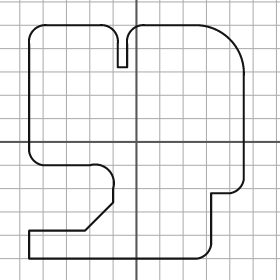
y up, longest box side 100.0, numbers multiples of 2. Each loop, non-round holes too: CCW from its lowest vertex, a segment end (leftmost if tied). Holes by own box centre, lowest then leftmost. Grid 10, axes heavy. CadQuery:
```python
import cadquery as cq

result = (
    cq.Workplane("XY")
    .moveTo(-46.0, -50.0)
    .lineTo(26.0, -50.0)
    .threePointArc((30.0, -48.0), (32.0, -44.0))
    .lineTo(32.0, -22.0)
    .lineTo(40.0, -22.0)
    .threePointArc((44.0, -20.0), (46.0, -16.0))
    .lineTo(46.0, 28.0)
    .threePointArc((40.0, 44.0), (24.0, 50.0))
    .lineTo(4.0, 50.0)
    .threePointArc((-2.0, 48.0), (-4.0, 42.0))
    .lineTo(-4.0, 32.0)
    .lineTo(-8.0, 32.0)
    .lineTo(-8.0, 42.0)
    .threePointArc((-10.0, 48.0), (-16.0, 50.0))
    .lineTo(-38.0, 50.0)
    .threePointArc((-44.0, 48.0), (-46.0, 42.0))
    .lineTo(-46.0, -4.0)
    .threePointArc((-44.0, -8.0), (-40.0, -10.0))
    .lineTo(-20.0, -10.0)
    .threePointArc((-12.0, -12.0), (-10.0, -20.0))
    .lineTo(-10.0, -26.0)
    .lineTo(-22.0, -38.0)
    .lineTo(-46.0, -38.0)
    .close()
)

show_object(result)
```